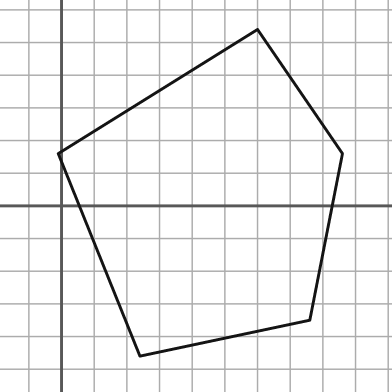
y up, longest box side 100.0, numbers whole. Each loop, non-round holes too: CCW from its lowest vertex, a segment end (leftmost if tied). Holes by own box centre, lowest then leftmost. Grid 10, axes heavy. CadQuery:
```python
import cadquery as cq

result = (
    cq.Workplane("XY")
    .moveTo(24.0, -46.0)
    .lineTo(76.0, -35.0)
    .lineTo(86.0, 16.0)
    .lineTo(60.0, 54.0)
    .lineTo(-1.0, 16.0)
    .close()
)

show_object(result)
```